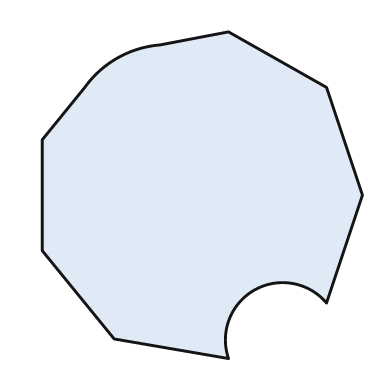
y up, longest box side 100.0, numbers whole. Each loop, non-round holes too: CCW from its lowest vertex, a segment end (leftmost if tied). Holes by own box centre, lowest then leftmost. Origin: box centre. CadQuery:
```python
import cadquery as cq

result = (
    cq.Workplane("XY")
    .moveTo(8.0, -50.0)
    .threePointArc((16.0, -29.0), (38.0, -33.0))
    .lineTo(49.0, 0.0)
    .lineTo(38.0, 33.0)
    .lineTo(8.0, 50.0)
    .lineTo(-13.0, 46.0)
    .threePointArc((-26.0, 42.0), (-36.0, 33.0))
    .lineTo(-49.0, 17.0)
    .lineTo(-49.0, -17.0)
    .lineTo(-27.0, -44.0)
    .close()
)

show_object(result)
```